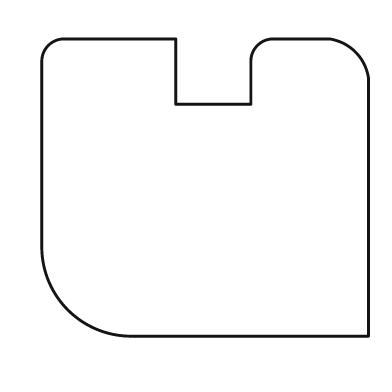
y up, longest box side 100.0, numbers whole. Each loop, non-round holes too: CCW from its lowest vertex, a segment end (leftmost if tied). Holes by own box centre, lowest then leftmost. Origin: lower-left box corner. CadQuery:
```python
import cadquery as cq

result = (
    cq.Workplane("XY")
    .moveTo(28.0, 0.0)
    .lineTo(100.0, 0.0)
    .lineTo(100.0, 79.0)
    .threePointArc((96.0, 87.0), (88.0, 91.0))
    .lineTo(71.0, 91.0)
    .threePointArc((66.0, 89.0), (64.0, 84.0))
    .lineTo(64.0, 71.0)
    .lineTo(41.0, 71.0)
    .lineTo(41.0, 91.0)
    .lineTo(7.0, 91.0)
    .threePointArc((2.0, 89.0), (0.0, 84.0))
    .lineTo(0.0, 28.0)
    .threePointArc((8.0, 8.0), (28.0, 0.0))
    .close()
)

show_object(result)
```